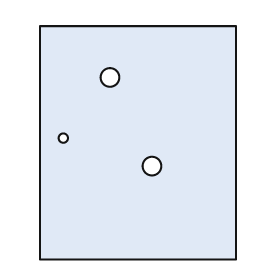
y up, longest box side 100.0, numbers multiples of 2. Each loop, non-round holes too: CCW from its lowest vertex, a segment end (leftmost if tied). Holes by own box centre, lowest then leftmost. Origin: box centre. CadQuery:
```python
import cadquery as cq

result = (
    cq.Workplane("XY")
    .moveTo(-42.0, -50.0)
    .lineTo(42.0, -50.0)
    .lineTo(42.0, 50.0)
    .lineTo(-42.0, 50.0)
    .close()
    .moveTo(6.0, -10.0)
    .circle(4.0)
    .moveTo(-32.0, 2.0)
    .circle(2.0)
    .moveTo(-12.0, 28.0)
    .circle(4.0)
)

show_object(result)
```